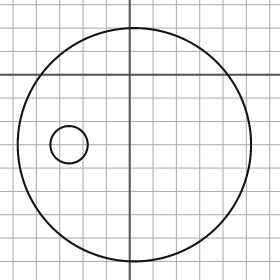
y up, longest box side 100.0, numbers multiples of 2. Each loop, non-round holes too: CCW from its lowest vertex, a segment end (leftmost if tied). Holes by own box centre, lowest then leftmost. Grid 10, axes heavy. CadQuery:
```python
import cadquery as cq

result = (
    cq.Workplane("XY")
    .moveTo(2.0, -30.0)
    .circle(50.0)
    .moveTo(-26.0, -30.0)
    .circle(8.0)
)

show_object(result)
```